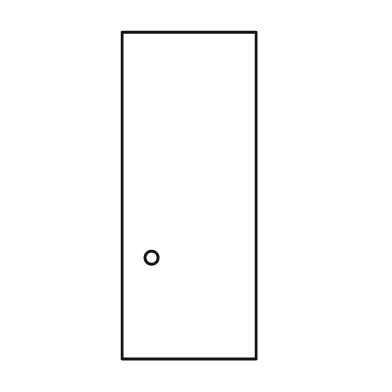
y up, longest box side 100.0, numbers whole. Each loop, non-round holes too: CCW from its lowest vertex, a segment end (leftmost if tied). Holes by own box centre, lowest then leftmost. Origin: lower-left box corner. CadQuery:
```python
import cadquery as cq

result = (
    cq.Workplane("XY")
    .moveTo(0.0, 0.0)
    .lineTo(41.0, 0.0)
    .lineTo(41.0, 100.0)
    .lineTo(0.0, 100.0)
    .close()
    .moveTo(9.0, 31.0)
    .circle(2.0)
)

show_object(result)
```